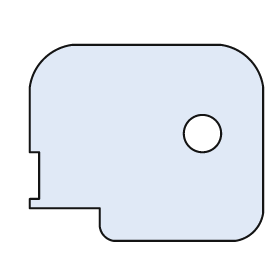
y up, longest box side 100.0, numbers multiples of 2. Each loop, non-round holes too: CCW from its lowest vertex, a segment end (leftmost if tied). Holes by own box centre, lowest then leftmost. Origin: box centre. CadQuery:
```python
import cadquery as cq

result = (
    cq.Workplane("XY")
    .moveTo(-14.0, -42.0)
    .lineTo(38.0, -42.0)
    .threePointArc((46.0, -38.0), (50.0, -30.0))
    .lineTo(50.0, 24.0)
    .threePointArc((44.0, 36.0), (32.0, 42.0))
    .lineTo(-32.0, 42.0)
    .threePointArc((-44.0, 36.0), (-50.0, 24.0))
    .lineTo(-50.0, -4.0)
    .lineTo(-46.0, -4.0)
    .lineTo(-46.0, -24.0)
    .lineTo(-50.0, -24.0)
    .lineTo(-50.0, -28.0)
    .lineTo(-20.0, -28.0)
    .lineTo(-20.0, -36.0)
    .threePointArc((-18.0, -40.0), (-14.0, -42.0))
    .close()
    .moveTo(24.0, 4.0)
    .circle(8.0)
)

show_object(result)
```